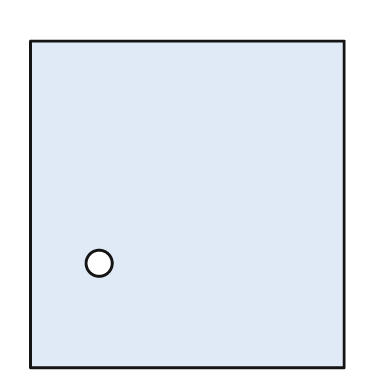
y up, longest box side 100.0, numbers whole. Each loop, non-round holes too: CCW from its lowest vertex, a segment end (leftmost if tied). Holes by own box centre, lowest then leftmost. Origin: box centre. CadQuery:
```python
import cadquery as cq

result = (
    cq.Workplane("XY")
    .moveTo(-48.0, -50.0)
    .lineTo(48.0, -50.0)
    .lineTo(48.0, 50.0)
    .lineTo(-48.0, 50.0)
    .close()
    .moveTo(-27.0, -18.0)
    .circle(4.0)
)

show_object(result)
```